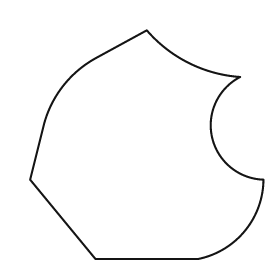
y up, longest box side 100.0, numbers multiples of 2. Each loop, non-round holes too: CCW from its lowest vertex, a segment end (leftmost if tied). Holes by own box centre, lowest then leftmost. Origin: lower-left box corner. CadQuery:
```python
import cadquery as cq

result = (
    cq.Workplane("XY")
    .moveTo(28.0, 0.0)
    .lineTo(72.0, 0.0)
    .threePointArc((92.0, 12.0), (100.0, 34.0))
    .threePointArc((78.0, 52.0), (90.0, 78.0))
    .threePointArc((68.0, 84.0), (50.0, 98.0))
    .lineTo(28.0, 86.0)
    .threePointArc((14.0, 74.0), (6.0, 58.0))
    .lineTo(0.0, 34.0)
    .close()
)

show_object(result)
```